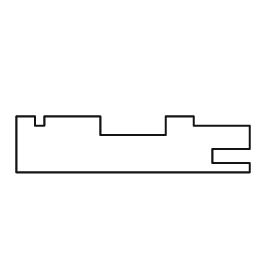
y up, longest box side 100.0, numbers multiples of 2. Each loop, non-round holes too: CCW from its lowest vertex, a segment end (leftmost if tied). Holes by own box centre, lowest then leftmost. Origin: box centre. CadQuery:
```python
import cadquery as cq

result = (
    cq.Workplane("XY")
    .moveTo(-50.0, -12.0)
    .lineTo(50.0, -12.0)
    .lineTo(50.0, -8.0)
    .lineTo(34.0, -8.0)
    .lineTo(34.0, -2.0)
    .lineTo(50.0, -2.0)
    .lineTo(50.0, 8.0)
    .lineTo(26.0, 8.0)
    .lineTo(26.0, 12.0)
    .lineTo(14.0, 12.0)
    .lineTo(14.0, 4.0)
    .lineTo(-14.0, 4.0)
    .lineTo(-14.0, 12.0)
    .lineTo(-38.0, 12.0)
    .lineTo(-38.0, 8.0)
    .lineTo(-42.0, 8.0)
    .lineTo(-42.0, 12.0)
    .lineTo(-50.0, 12.0)
    .close()
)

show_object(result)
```